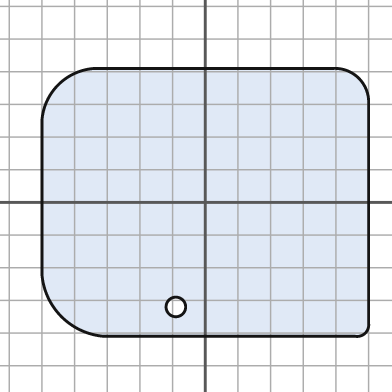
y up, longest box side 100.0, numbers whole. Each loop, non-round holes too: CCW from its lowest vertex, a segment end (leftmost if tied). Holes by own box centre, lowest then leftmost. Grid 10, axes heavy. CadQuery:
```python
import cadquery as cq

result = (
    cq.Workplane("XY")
    .moveTo(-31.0, -41.0)
    .lineTo(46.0, -41.0)
    .threePointArc((49.0, -40.0), (50.0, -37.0))
    .lineTo(50.0, 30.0)
    .threePointArc((47.0, 38.0), (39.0, 41.0))
    .lineTo(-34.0, 41.0)
    .threePointArc((-45.0, 36.0), (-50.0, 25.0))
    .lineTo(-50.0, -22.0)
    .threePointArc((-44.0, -35.0), (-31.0, -41.0))
    .close()
    .moveTo(-9.0, -32.0)
    .circle(3.0)
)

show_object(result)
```